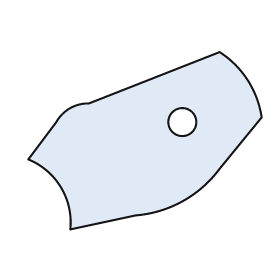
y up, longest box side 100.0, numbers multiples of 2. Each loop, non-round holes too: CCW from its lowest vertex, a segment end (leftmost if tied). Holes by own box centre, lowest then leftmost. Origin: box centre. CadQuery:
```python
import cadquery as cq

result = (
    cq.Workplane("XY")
    .moveTo(-32.0, -38.0)
    .lineTo(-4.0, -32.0)
    .threePointArc((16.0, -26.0), (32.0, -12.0))
    .lineTo(50.0, 10.0)
    .threePointArc((44.0, 26.0), (32.0, 38.0))
    .lineTo(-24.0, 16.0)
    .threePointArc((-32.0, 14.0), (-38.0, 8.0))
    .lineTo(-50.0, -8.0)
    .threePointArc((-36.0, -20.0), (-32.0, -38.0))
    .close()
    .moveTo(16.0, 8.0)
    .circle(6.0)
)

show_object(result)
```